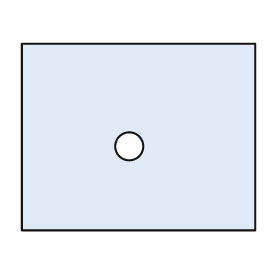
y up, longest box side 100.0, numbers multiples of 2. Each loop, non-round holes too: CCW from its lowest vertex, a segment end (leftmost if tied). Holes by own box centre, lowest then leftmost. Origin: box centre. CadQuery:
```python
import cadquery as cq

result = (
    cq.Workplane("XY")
    .moveTo(-50.0, -40.0)
    .lineTo(50.0, -40.0)
    .lineTo(50.0, 40.0)
    .lineTo(-50.0, 40.0)
    .close()
    .moveTo(-4.0, -4.0)
    .circle(6.0)
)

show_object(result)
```